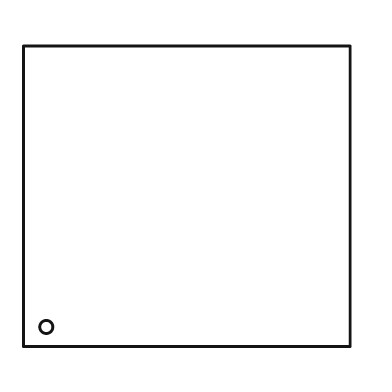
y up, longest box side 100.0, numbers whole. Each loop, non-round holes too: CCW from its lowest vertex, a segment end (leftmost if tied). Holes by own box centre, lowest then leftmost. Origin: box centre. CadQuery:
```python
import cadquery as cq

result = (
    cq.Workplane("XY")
    .moveTo(-50.0, -46.0)
    .lineTo(50.0, -46.0)
    .lineTo(50.0, 46.0)
    .lineTo(-50.0, 46.0)
    .close()
    .moveTo(-43.0, -40.0)
    .circle(2.0)
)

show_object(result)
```